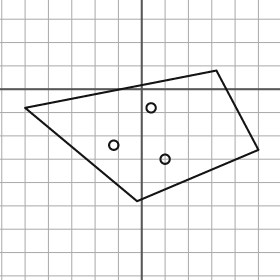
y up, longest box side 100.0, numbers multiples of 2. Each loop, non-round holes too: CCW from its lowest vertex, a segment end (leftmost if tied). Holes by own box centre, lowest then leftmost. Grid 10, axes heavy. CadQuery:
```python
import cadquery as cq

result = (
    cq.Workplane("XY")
    .moveTo(-2.0, -48.0)
    .lineTo(50.0, -26.0)
    .lineTo(32.0, 8.0)
    .lineTo(-50.0, -8.0)
    .close()
    .moveTo(10.0, -30.0)
    .circle(2.0)
    .moveTo(-12.0, -24.0)
    .circle(2.0)
    .moveTo(4.0, -8.0)
    .circle(2.0)
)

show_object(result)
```